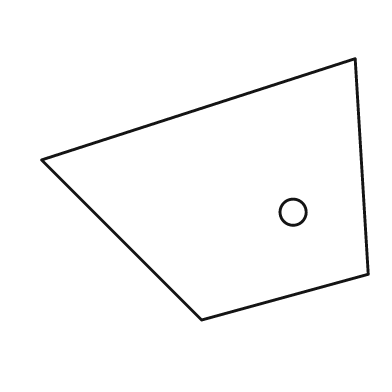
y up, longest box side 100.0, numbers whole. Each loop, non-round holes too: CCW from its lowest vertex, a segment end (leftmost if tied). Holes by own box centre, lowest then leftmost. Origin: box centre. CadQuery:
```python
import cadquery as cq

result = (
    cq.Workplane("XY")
    .moveTo(-1.0, -40.0)
    .lineTo(50.0, -26.0)
    .lineTo(46.0, 40.0)
    .lineTo(-50.0, 9.0)
    .close()
    .moveTo(27.0, -7.0)
    .circle(4.0)
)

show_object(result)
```